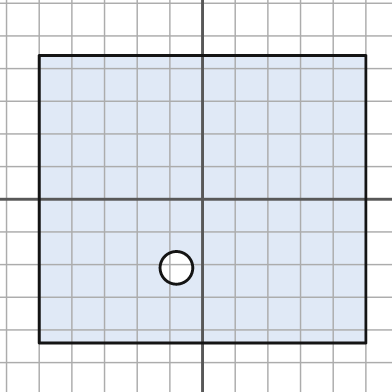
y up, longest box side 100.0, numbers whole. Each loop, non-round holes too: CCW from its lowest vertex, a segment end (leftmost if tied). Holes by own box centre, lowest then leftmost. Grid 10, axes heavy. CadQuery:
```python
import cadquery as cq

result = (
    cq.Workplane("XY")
    .moveTo(-50.0, -44.0)
    .lineTo(50.0, -44.0)
    .lineTo(50.0, 44.0)
    .lineTo(-50.0, 44.0)
    .close()
    .moveTo(-8.0, -21.0)
    .circle(5.0)
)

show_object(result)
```